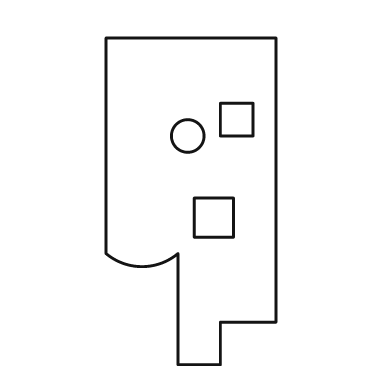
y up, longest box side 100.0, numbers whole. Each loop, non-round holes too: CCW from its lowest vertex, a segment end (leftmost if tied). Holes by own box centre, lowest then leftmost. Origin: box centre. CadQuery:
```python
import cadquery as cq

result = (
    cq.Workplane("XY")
    .moveTo(-4.0, -50.0)
    .lineTo(9.0, -50.0)
    .lineTo(9.0, -37.0)
    .lineTo(26.0, -37.0)
    .lineTo(26.0, 50.0)
    .lineTo(-26.0, 50.0)
    .lineTo(-26.0, -16.0)
    .threePointArc((-15.0, -20.0), (-4.0, -16.0))
    .close()
    .moveTo(1.0, -11.0)
    .lineTo(13.0, -11.0)
    .lineTo(13.0, 1.0)
    .lineTo(1.0, 1.0)
    .close()
    .moveTo(-1.0, 20.0)
    .circle(5.0)
    .moveTo(9.0, 20.0)
    .lineTo(19.0, 20.0)
    .lineTo(19.0, 30.0)
    .lineTo(9.0, 30.0)
    .close()
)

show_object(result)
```